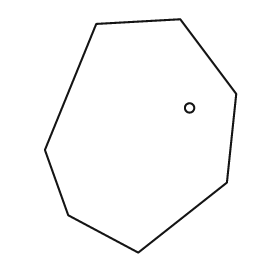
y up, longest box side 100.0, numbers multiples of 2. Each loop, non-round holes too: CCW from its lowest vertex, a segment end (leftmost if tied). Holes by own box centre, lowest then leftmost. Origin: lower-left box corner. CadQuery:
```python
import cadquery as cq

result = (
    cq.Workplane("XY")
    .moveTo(40.0, 0.0)
    .lineTo(78.0, 30.0)
    .lineTo(82.0, 68.0)
    .lineTo(58.0, 100.0)
    .lineTo(22.0, 98.0)
    .lineTo(0.0, 44.0)
    .lineTo(10.0, 16.0)
    .close()
    .moveTo(62.0, 62.0)
    .circle(2.0)
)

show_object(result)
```